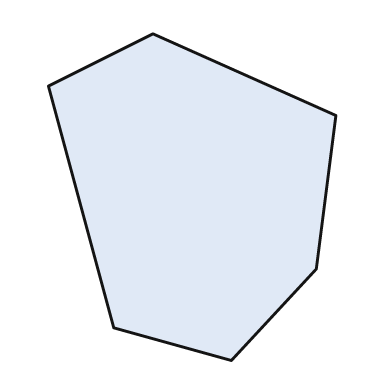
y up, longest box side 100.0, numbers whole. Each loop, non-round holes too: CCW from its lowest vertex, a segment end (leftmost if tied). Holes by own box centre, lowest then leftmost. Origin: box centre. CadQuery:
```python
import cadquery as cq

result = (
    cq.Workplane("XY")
    .moveTo(12.0, -50.0)
    .lineTo(38.0, -22.0)
    .lineTo(44.0, 25.0)
    .lineTo(-12.0, 50.0)
    .lineTo(-44.0, 34.0)
    .lineTo(-24.0, -40.0)
    .close()
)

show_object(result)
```